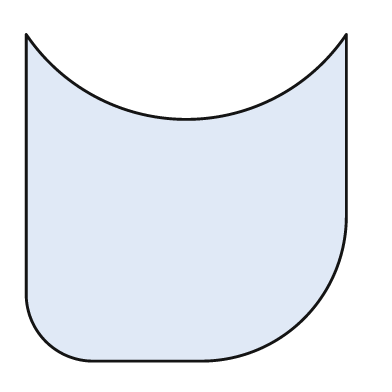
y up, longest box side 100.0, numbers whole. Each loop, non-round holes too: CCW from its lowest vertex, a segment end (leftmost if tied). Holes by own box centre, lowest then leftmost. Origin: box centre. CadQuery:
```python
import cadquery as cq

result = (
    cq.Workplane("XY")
    .moveTo(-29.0, -50.0)
    .lineTo(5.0, -50.0)
    .threePointArc((36.0, -37.0), (49.0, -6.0))
    .lineTo(49.0, 50.0)
    .threePointArc((0.0, 24.0), (-49.0, 50.0))
    .lineTo(-49.0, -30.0)
    .threePointArc((-43.0, -44.0), (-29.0, -50.0))
    .close()
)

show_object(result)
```